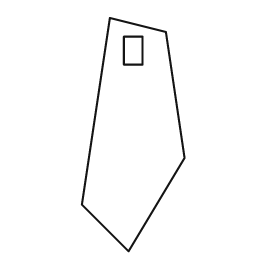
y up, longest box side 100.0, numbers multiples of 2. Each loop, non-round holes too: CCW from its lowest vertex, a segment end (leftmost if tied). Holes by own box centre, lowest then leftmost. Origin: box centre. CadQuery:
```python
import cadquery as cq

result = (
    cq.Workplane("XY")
    .moveTo(-2.0, -50.0)
    .lineTo(22.0, -10.0)
    .lineTo(14.0, 44.0)
    .lineTo(-10.0, 50.0)
    .lineTo(-22.0, -30.0)
    .close()
    .moveTo(-4.0, 30.0)
    .lineTo(4.0, 30.0)
    .lineTo(4.0, 42.0)
    .lineTo(-4.0, 42.0)
    .close()
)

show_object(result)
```